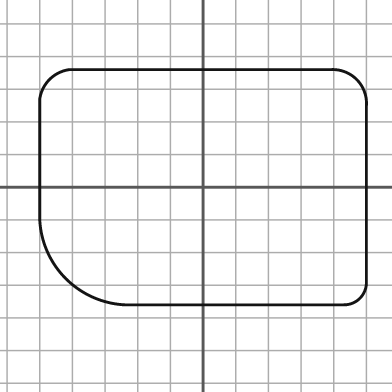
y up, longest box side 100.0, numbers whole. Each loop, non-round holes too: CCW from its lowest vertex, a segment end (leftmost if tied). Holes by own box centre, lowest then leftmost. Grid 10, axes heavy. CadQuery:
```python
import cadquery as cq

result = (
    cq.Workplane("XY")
    .moveTo(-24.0, -36.0)
    .lineTo(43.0, -36.0)
    .threePointArc((48.0, -34.0), (50.0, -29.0))
    .lineTo(50.0, 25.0)
    .threePointArc((47.0, 33.0), (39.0, 36.0))
    .lineTo(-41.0, 36.0)
    .threePointArc((-47.0, 33.0), (-50.0, 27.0))
    .lineTo(-50.0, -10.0)
    .threePointArc((-42.0, -28.0), (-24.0, -36.0))
    .close()
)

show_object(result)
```